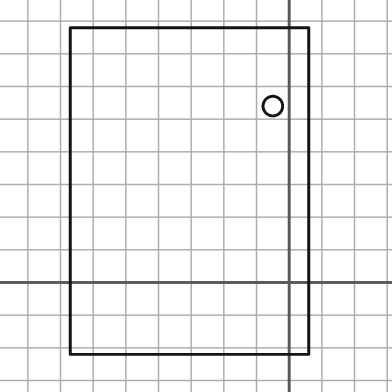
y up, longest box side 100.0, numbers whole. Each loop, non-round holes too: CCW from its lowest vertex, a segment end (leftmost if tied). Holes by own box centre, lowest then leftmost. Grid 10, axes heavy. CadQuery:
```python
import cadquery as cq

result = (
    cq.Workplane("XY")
    .moveTo(-67.0, -22.0)
    .lineTo(6.0, -22.0)
    .lineTo(6.0, 78.0)
    .lineTo(-67.0, 78.0)
    .close()
    .moveTo(-5.0, 54.0)
    .circle(3.0)
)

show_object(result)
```